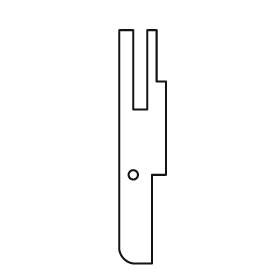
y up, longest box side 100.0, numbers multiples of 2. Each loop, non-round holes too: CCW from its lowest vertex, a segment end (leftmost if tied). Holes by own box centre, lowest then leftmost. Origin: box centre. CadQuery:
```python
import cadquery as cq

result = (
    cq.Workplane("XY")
    .moveTo(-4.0, -50.0)
    .lineTo(4.0, -50.0)
    .lineTo(4.0, -12.0)
    .lineTo(10.0, -12.0)
    .lineTo(10.0, 28.0)
    .lineTo(6.0, 28.0)
    .lineTo(6.0, 50.0)
    .lineTo(2.0, 50.0)
    .lineTo(2.0, 16.0)
    .lineTo(-4.0, 16.0)
    .lineTo(-4.0, 50.0)
    .lineTo(-10.0, 50.0)
    .lineTo(-10.0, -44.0)
    .threePointArc((-8.0, -48.0), (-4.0, -50.0))
    .close()
    .moveTo(-4.0, -12.0)
    .circle(2.0)
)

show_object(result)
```